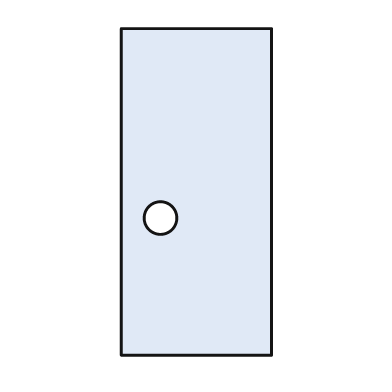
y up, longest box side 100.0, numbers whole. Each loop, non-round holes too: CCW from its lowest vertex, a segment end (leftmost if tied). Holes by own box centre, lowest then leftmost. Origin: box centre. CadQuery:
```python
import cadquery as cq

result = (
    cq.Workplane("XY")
    .moveTo(-23.0, -50.0)
    .lineTo(23.0, -50.0)
    .lineTo(23.0, 50.0)
    .lineTo(-23.0, 50.0)
    .close()
    .moveTo(-11.0, -8.0)
    .circle(5.0)
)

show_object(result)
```